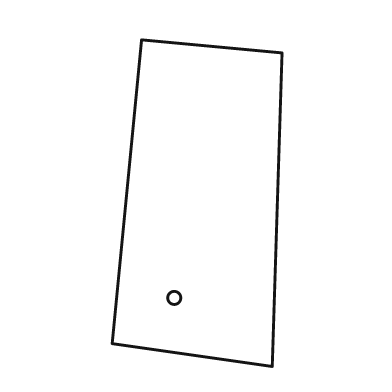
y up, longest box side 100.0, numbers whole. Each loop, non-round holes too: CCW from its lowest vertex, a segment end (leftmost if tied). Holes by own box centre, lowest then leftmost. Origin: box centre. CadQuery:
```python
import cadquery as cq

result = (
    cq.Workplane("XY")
    .moveTo(23.0, -50.0)
    .lineTo(26.0, 46.0)
    .lineTo(-17.0, 50.0)
    .lineTo(-26.0, -43.0)
    .close()
    .moveTo(-7.0, -29.0)
    .circle(2.0)
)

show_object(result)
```